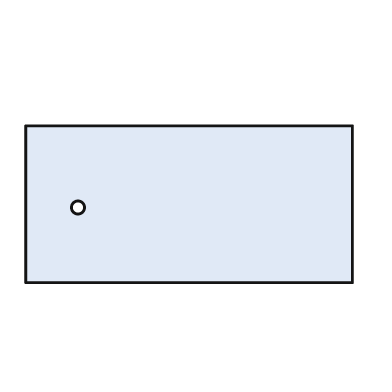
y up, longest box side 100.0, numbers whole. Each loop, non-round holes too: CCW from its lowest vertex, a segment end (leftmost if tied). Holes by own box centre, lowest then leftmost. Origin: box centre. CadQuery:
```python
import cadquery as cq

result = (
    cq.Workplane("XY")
    .moveTo(-50.0, -24.0)
    .lineTo(50.0, -24.0)
    .lineTo(50.0, 24.0)
    .lineTo(-50.0, 24.0)
    .close()
    .moveTo(-34.0, -1.0)
    .circle(2.0)
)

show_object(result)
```